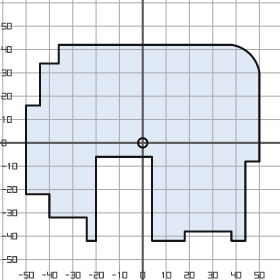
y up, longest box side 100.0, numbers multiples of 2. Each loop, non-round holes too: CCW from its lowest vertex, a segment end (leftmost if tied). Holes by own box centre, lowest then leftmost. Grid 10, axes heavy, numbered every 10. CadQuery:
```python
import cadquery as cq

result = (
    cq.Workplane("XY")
    .moveTo(-24.0, -42.0)
    .lineTo(-20.0, -42.0)
    .lineTo(-20.0, -6.0)
    .lineTo(4.0, -6.0)
    .lineTo(4.0, -42.0)
    .lineTo(18.0, -42.0)
    .lineTo(18.0, -38.0)
    .lineTo(38.0, -38.0)
    .lineTo(38.0, -42.0)
    .lineTo(44.0, -42.0)
    .lineTo(44.0, -8.0)
    .lineTo(50.0, -8.0)
    .lineTo(50.0, 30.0)
    .threePointArc((46.0, 38.0), (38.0, 42.0))
    .lineTo(-36.0, 42.0)
    .lineTo(-36.0, 34.0)
    .lineTo(-44.0, 34.0)
    .lineTo(-44.0, 16.0)
    .lineTo(-50.0, 16.0)
    .lineTo(-50.0, -22.0)
    .lineTo(-40.0, -22.0)
    .lineTo(-40.0, -32.0)
    .lineTo(-24.0, -32.0)
    .close()
    .moveTo(0.0, 0.0)
    .circle(2.0)
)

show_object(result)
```